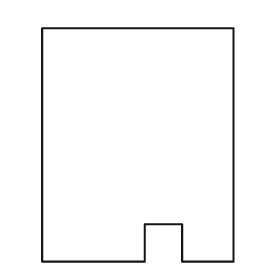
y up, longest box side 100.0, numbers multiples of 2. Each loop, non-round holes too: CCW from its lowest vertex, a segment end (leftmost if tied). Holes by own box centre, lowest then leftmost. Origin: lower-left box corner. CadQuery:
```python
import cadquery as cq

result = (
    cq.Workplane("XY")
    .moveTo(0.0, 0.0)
    .lineTo(44.0, 0.0)
    .lineTo(44.0, 16.0)
    .lineTo(60.0, 16.0)
    .lineTo(60.0, 0.0)
    .lineTo(82.0, 0.0)
    .lineTo(82.0, 100.0)
    .lineTo(0.0, 100.0)
    .close()
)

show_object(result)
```